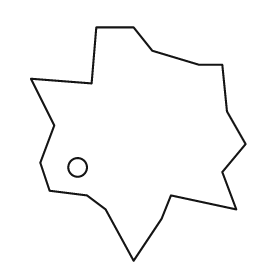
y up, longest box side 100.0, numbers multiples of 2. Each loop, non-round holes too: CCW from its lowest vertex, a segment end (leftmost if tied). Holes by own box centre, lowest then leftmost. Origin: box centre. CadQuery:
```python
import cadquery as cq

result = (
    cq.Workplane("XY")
    .moveTo(-2.0, -50.0)
    .lineTo(10.0, -32.0)
    .lineTo(14.0, -22.0)
    .lineTo(42.0, -28.0)
    .lineTo(36.0, -12.0)
    .lineTo(46.0, 0.0)
    .lineTo(38.0, 14.0)
    .lineTo(36.0, 34.0)
    .lineTo(26.0, 34.0)
    .lineTo(6.0, 40.0)
    .lineTo(-2.0, 50.0)
    .lineTo(-18.0, 50.0)
    .lineTo(-20.0, 26.0)
    .lineTo(-46.0, 28.0)
    .lineTo(-36.0, 8.0)
    .lineTo(-42.0, -8.0)
    .lineTo(-38.0, -20.0)
    .lineTo(-22.0, -22.0)
    .lineTo(-14.0, -28.0)
    .close()
    .moveTo(-26.0, -10.0)
    .circle(4.0)
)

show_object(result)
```